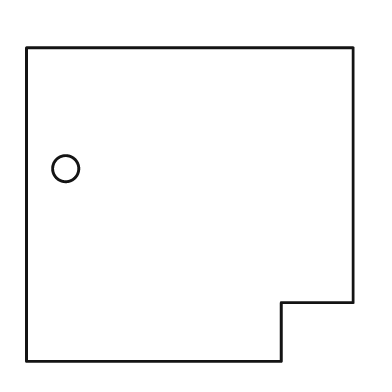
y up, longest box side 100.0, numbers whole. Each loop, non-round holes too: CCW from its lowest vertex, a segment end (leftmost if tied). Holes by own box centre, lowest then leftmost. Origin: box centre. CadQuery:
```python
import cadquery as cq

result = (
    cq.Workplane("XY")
    .moveTo(-50.0, -48.0)
    .lineTo(28.0, -48.0)
    .lineTo(28.0, -30.0)
    .lineTo(50.0, -30.0)
    .lineTo(50.0, 48.0)
    .lineTo(-50.0, 48.0)
    .close()
    .moveTo(-38.0, 11.0)
    .circle(4.0)
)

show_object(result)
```